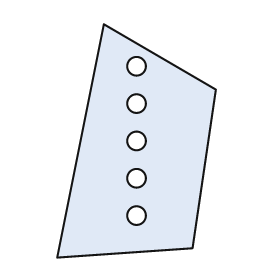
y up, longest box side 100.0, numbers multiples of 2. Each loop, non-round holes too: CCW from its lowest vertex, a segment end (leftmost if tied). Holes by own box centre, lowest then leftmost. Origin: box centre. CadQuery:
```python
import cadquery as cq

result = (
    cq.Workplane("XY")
    .moveTo(-34.0, -50.0)
    .lineTo(24.0, -46.0)
    .lineTo(34.0, 22.0)
    .lineTo(-14.0, 50.0)
    .close()
    .moveTo(0.0, -32.0)
    .circle(4.0)
    .moveTo(0.0, -16.0)
    .circle(4.0)
    .moveTo(0.0, 0.0)
    .circle(4.0)
    .moveTo(0.0, 16.0)
    .circle(4.0)
    .moveTo(0.0, 32.0)
    .circle(4.0)
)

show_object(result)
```